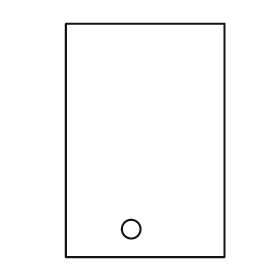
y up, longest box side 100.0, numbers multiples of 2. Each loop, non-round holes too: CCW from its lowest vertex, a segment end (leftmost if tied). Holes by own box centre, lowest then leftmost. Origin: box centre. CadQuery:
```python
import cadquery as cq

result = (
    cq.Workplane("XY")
    .moveTo(-34.0, -50.0)
    .lineTo(34.0, -50.0)
    .lineTo(34.0, 50.0)
    .lineTo(-34.0, 50.0)
    .close()
    .moveTo(-6.0, -38.0)
    .circle(4.0)
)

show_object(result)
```